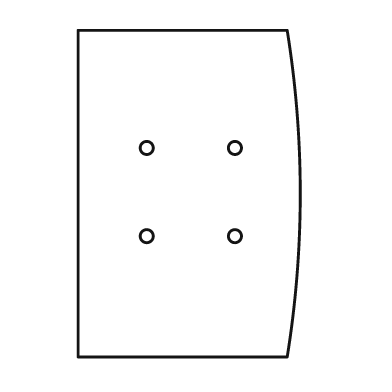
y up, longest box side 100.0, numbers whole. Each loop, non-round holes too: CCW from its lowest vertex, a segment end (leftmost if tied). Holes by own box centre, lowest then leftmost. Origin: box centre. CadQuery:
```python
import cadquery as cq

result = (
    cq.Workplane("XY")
    .moveTo(-34.0, -50.0)
    .lineTo(30.0, -50.0)
    .threePointArc((34.0, 0.0), (30.0, 50.0))
    .lineTo(-34.0, 50.0)
    .close()
    .moveTo(-13.0, -13.0)
    .circle(2.0)
    .moveTo(14.0, -13.0)
    .circle(2.0)
    .moveTo(-13.0, 14.0)
    .circle(2.0)
    .moveTo(14.0, 14.0)
    .circle(2.0)
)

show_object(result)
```